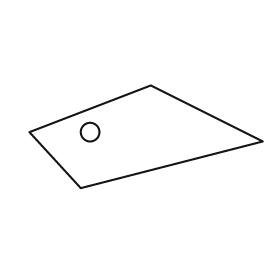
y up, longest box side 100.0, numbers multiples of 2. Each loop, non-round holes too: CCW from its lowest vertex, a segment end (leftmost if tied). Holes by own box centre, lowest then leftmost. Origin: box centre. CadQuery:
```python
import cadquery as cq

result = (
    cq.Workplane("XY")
    .moveTo(-28.0, -22.0)
    .lineTo(50.0, -2.0)
    .lineTo(2.0, 22.0)
    .lineTo(-50.0, 2.0)
    .close()
    .moveTo(-24.0, 2.0)
    .circle(4.0)
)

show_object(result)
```